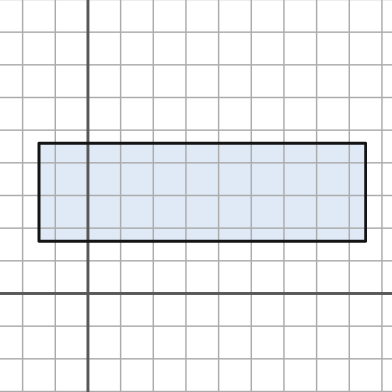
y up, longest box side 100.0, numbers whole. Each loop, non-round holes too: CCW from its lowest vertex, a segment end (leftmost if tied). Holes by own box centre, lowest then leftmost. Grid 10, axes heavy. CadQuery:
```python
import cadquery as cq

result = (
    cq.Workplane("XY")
    .moveTo(-15.0, 16.0)
    .lineTo(85.0, 16.0)
    .lineTo(85.0, 46.0)
    .lineTo(-15.0, 46.0)
    .close()
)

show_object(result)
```